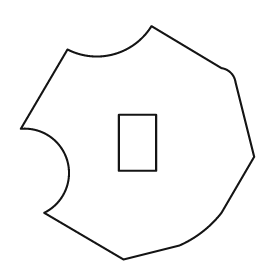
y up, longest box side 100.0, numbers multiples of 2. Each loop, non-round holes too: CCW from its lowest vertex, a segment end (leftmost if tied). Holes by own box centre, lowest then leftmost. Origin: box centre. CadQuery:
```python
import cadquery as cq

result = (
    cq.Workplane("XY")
    .moveTo(-6.0, -50.0)
    .lineTo(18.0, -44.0)
    .threePointArc((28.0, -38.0), (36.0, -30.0))
    .lineTo(50.0, -6.0)
    .lineTo(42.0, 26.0)
    .threePointArc((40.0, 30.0), (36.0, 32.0))
    .lineTo(6.0, 50.0)
    .threePointArc((-10.0, 38.0), (-30.0, 40.0))
    .lineTo(-50.0, 6.0)
    .threePointArc((-30.0, -8.0), (-40.0, -30.0))
    .close()
    .moveTo(-8.0, -12.0)
    .lineTo(8.0, -12.0)
    .lineTo(8.0, 12.0)
    .lineTo(-8.0, 12.0)
    .close()
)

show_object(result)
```